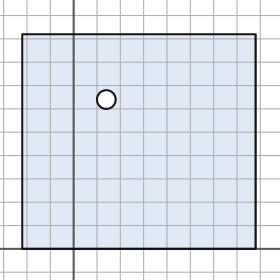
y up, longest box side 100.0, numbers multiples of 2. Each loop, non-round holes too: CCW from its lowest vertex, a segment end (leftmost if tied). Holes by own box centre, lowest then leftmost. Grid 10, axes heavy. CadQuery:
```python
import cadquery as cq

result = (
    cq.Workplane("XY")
    .moveTo(-22.0, 0.0)
    .lineTo(78.0, 0.0)
    .lineTo(78.0, 92.0)
    .lineTo(-22.0, 92.0)
    .close()
    .moveTo(14.0, 64.0)
    .circle(4.0)
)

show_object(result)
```